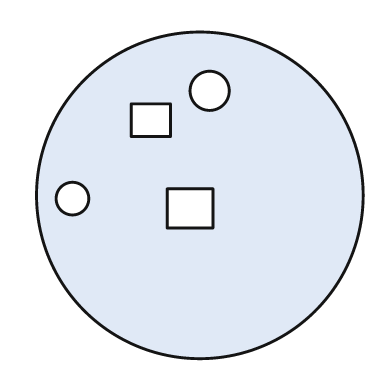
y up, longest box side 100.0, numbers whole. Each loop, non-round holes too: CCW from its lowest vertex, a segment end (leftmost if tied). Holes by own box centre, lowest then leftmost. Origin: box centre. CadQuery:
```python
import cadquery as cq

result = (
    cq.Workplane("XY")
    .moveTo(0.0, 0.0)
    .circle(50.0)
    .moveTo(-10.0, -10.0)
    .lineTo(4.0, -10.0)
    .lineTo(4.0, 2.0)
    .lineTo(-10.0, 2.0)
    .close()
    .moveTo(-39.0, -1.0)
    .circle(5.0)
    .moveTo(-21.0, 18.0)
    .lineTo(-9.0, 18.0)
    .lineTo(-9.0, 28.0)
    .lineTo(-21.0, 28.0)
    .close()
    .moveTo(3.0, 32.0)
    .circle(6.0)
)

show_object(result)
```